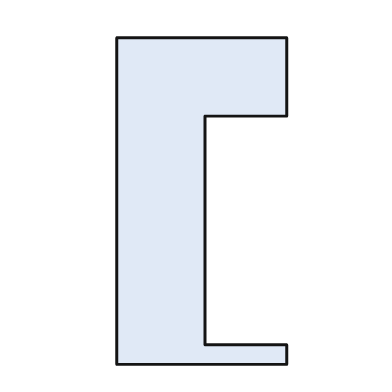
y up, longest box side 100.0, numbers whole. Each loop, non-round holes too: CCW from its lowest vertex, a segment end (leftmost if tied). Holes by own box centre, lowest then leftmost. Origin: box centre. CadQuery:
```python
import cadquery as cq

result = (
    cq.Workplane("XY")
    .moveTo(-26.0, -50.0)
    .lineTo(26.0, -50.0)
    .lineTo(26.0, -44.0)
    .lineTo(1.0, -44.0)
    .lineTo(1.0, 26.0)
    .lineTo(26.0, 26.0)
    .lineTo(26.0, 50.0)
    .lineTo(-26.0, 50.0)
    .close()
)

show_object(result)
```